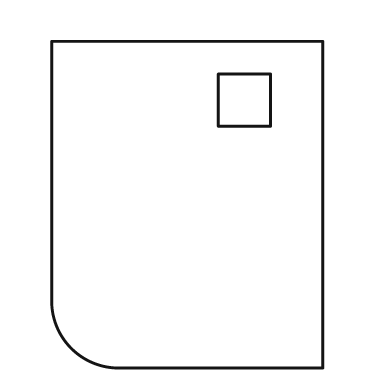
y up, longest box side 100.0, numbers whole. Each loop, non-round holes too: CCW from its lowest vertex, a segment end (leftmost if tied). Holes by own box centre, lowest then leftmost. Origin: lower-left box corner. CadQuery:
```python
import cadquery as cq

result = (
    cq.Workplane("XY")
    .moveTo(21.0, 0.0)
    .lineTo(83.0, 0.0)
    .lineTo(83.0, 100.0)
    .lineTo(0.0, 100.0)
    .lineTo(0.0, 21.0)
    .threePointArc((6.0, 6.0), (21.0, 0.0))
    .close()
    .moveTo(51.0, 74.0)
    .lineTo(67.0, 74.0)
    .lineTo(67.0, 90.0)
    .lineTo(51.0, 90.0)
    .close()
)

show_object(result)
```